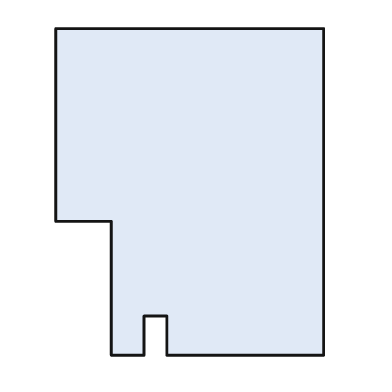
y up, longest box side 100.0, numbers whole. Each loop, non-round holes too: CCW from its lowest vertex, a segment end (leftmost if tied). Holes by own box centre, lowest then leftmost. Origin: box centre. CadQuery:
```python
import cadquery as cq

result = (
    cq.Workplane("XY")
    .moveTo(-24.0, -50.0)
    .lineTo(-14.0, -50.0)
    .lineTo(-14.0, -38.0)
    .lineTo(-7.0, -38.0)
    .lineTo(-7.0, -50.0)
    .lineTo(41.0, -50.0)
    .lineTo(41.0, 50.0)
    .lineTo(-41.0, 50.0)
    .lineTo(-41.0, -9.0)
    .lineTo(-24.0, -9.0)
    .close()
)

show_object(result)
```